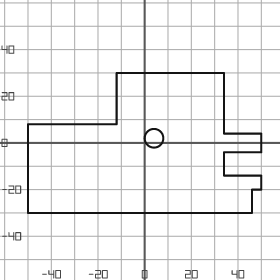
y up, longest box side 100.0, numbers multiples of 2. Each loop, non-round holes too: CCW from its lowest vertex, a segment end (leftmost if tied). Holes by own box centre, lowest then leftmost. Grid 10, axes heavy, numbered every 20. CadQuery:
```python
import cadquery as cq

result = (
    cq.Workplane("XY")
    .moveTo(-50.0, -30.0)
    .lineTo(46.0, -30.0)
    .lineTo(46.0, -20.0)
    .lineTo(50.0, -20.0)
    .lineTo(50.0, -14.0)
    .lineTo(34.0, -14.0)
    .lineTo(34.0, -4.0)
    .lineTo(50.0, -4.0)
    .lineTo(50.0, 4.0)
    .lineTo(34.0, 4.0)
    .lineTo(34.0, 30.0)
    .lineTo(-12.0, 30.0)
    .lineTo(-12.0, 8.0)
    .lineTo(-50.0, 8.0)
    .close()
    .moveTo(4.0, 2.0)
    .circle(4.0)
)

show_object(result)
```